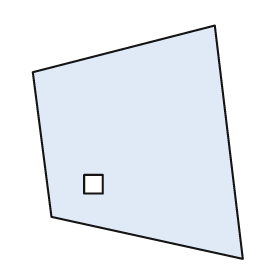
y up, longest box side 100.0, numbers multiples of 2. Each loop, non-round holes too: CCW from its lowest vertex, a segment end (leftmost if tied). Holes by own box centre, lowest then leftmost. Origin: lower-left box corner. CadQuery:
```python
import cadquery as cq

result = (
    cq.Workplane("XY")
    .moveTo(90.0, 0.0)
    .lineTo(78.0, 100.0)
    .lineTo(0.0, 80.0)
    .lineTo(8.0, 18.0)
    .close()
    .moveTo(22.0, 28.0)
    .lineTo(30.0, 28.0)
    .lineTo(30.0, 36.0)
    .lineTo(22.0, 36.0)
    .close()
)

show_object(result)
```